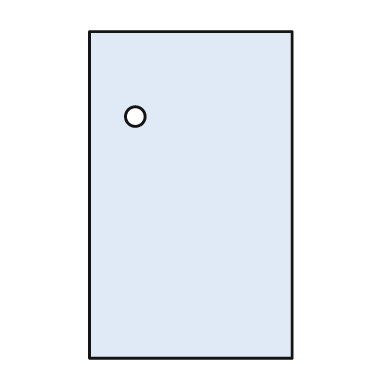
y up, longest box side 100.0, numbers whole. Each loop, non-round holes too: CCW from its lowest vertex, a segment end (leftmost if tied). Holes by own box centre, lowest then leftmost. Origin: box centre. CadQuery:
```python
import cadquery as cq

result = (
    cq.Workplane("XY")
    .moveTo(-31.0, -50.0)
    .lineTo(31.0, -50.0)
    .lineTo(31.0, 50.0)
    .lineTo(-31.0, 50.0)
    .close()
    .moveTo(-17.0, 24.0)
    .circle(3.0)
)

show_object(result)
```